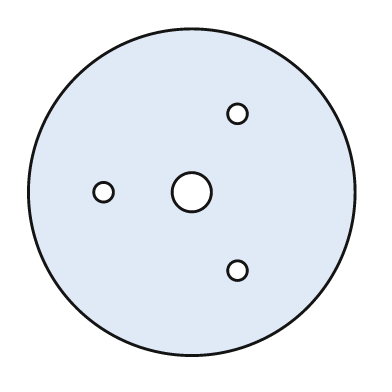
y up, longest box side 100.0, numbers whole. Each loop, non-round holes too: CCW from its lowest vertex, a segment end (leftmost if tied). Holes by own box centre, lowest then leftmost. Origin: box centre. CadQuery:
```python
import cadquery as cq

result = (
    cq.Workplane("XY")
    .moveTo(0.0, 0.0)
    .circle(50.0)
    .moveTo(14.0, -24.0)
    .circle(3.0)
    .moveTo(-27.0, 0.0)
    .circle(3.0)
    .moveTo(0.0, 0.0)
    .circle(6.0)
    .moveTo(14.0, 24.0)
    .circle(3.0)
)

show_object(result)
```